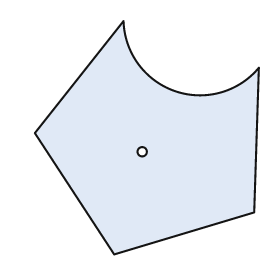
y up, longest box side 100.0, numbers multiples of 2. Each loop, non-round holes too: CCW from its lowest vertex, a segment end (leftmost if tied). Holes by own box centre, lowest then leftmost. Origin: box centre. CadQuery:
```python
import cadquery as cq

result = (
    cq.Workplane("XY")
    .moveTo(-14.0, -50.0)
    .lineTo(46.0, -32.0)
    .lineTo(48.0, 30.0)
    .threePointArc((12.0, 20.0), (-10.0, 50.0))
    .lineTo(-48.0, 2.0)
    .close()
    .moveTo(-2.0, -6.0)
    .circle(2.0)
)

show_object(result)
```